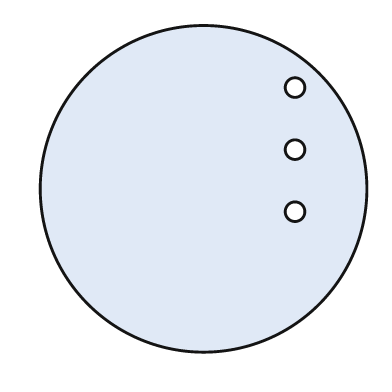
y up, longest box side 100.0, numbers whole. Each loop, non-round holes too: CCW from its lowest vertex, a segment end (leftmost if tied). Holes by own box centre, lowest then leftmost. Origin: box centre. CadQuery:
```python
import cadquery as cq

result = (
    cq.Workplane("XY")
    .moveTo(0.0, 0.0)
    .circle(50.0)
    .moveTo(28.0, -7.0)
    .circle(3.0)
    .moveTo(28.0, 12.0)
    .circle(3.0)
    .moveTo(28.0, 31.0)
    .circle(3.0)
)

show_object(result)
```